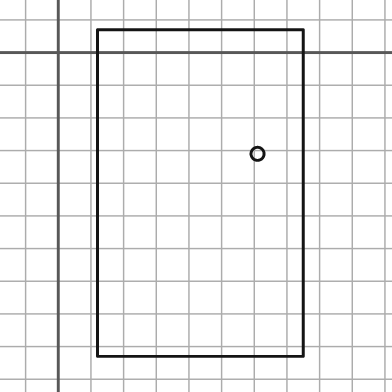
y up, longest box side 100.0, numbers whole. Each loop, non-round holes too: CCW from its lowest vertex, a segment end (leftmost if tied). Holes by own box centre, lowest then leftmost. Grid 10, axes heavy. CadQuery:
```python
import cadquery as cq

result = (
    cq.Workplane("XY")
    .moveTo(12.0, -93.0)
    .lineTo(75.0, -93.0)
    .lineTo(75.0, 7.0)
    .lineTo(12.0, 7.0)
    .close()
    .moveTo(61.0, -31.0)
    .circle(2.0)
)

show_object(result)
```